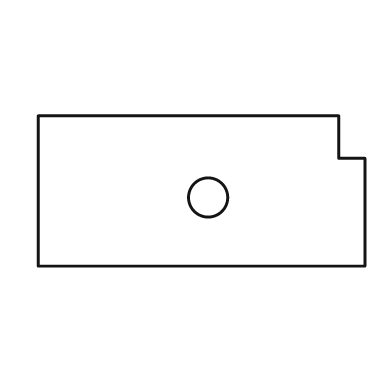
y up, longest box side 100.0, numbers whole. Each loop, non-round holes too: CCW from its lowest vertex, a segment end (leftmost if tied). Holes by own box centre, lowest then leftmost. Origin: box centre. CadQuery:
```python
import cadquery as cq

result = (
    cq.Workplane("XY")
    .moveTo(-50.0, -23.0)
    .lineTo(50.0, -23.0)
    .lineTo(50.0, 10.0)
    .lineTo(42.0, 10.0)
    .lineTo(42.0, 23.0)
    .lineTo(-50.0, 23.0)
    .close()
    .moveTo(2.0, -2.0)
    .circle(6.0)
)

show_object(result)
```